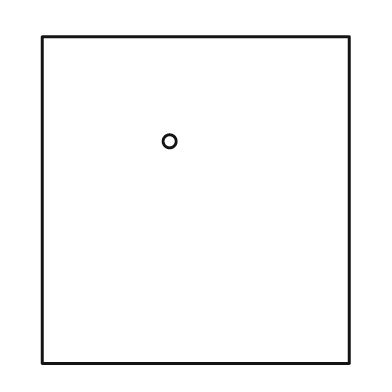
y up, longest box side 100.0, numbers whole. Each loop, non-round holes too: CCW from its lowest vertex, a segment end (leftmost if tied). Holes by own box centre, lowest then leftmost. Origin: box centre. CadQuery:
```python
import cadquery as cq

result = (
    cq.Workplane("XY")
    .moveTo(-47.0, -50.0)
    .lineTo(47.0, -50.0)
    .lineTo(47.0, 50.0)
    .lineTo(-47.0, 50.0)
    .close()
    .moveTo(-8.0, 18.0)
    .circle(2.0)
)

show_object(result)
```